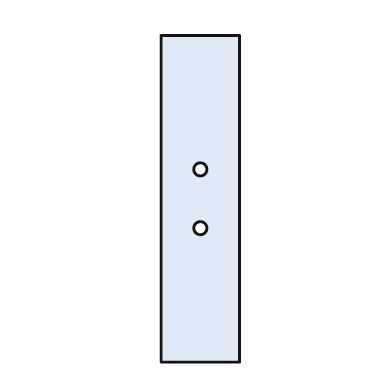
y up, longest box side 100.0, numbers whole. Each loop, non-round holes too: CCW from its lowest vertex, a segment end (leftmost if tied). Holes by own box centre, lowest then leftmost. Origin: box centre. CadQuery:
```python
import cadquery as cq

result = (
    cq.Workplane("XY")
    .moveTo(-12.0, -50.0)
    .lineTo(12.0, -50.0)
    .lineTo(12.0, 50.0)
    .lineTo(-12.0, 50.0)
    .close()
    .moveTo(0.0, -9.0)
    .circle(2.0)
    .moveTo(0.0, 9.0)
    .circle(2.0)
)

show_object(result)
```